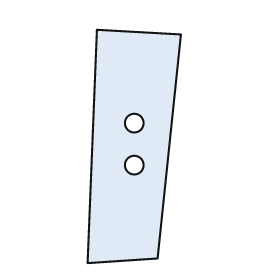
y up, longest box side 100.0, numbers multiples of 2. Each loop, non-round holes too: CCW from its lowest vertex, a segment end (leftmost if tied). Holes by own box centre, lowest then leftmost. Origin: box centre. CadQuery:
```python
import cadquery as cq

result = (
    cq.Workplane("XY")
    .moveTo(-20.0, -50.0)
    .lineTo(10.0, -48.0)
    .lineTo(20.0, 48.0)
    .lineTo(-16.0, 50.0)
    .close()
    .moveTo(0.0, -8.0)
    .circle(4.0)
    .moveTo(0.0, 10.0)
    .circle(4.0)
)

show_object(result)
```